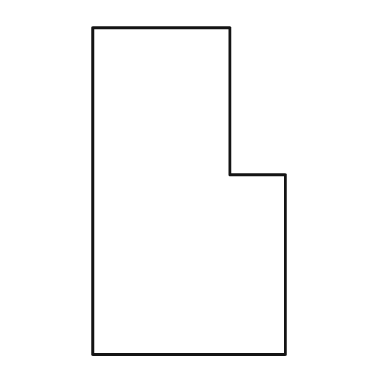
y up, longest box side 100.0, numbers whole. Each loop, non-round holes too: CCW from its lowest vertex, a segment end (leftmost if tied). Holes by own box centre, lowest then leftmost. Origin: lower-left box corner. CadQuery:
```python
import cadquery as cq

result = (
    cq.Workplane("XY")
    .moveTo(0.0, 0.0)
    .lineTo(59.0, 0.0)
    .lineTo(59.0, 55.0)
    .lineTo(42.0, 55.0)
    .lineTo(42.0, 100.0)
    .lineTo(0.0, 100.0)
    .close()
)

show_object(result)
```